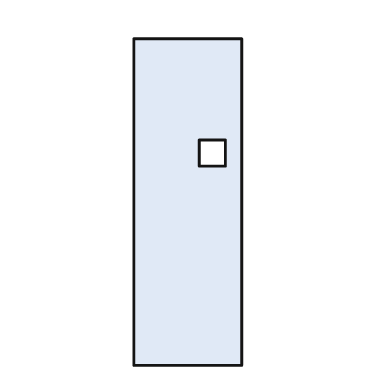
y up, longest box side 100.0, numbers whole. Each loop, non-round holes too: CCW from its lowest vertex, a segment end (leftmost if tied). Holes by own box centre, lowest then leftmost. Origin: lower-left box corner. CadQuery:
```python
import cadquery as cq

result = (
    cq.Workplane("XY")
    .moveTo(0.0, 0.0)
    .lineTo(33.0, 0.0)
    .lineTo(33.0, 100.0)
    .lineTo(0.0, 100.0)
    .close()
    .moveTo(20.0, 61.0)
    .lineTo(28.0, 61.0)
    .lineTo(28.0, 69.0)
    .lineTo(20.0, 69.0)
    .close()
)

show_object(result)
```